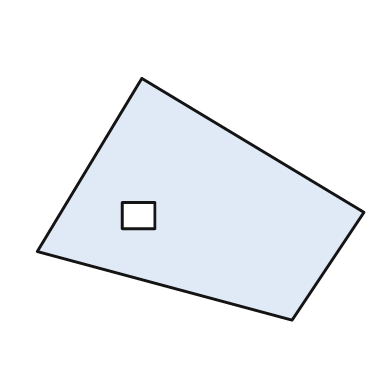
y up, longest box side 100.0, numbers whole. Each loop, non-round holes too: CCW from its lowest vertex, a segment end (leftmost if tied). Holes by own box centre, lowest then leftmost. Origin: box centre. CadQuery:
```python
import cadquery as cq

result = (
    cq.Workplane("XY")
    .moveTo(28.0, -37.0)
    .lineTo(50.0, -4.0)
    .lineTo(-18.0, 37.0)
    .lineTo(-50.0, -16.0)
    .close()
    .moveTo(-24.0, -9.0)
    .lineTo(-14.0, -9.0)
    .lineTo(-14.0, -1.0)
    .lineTo(-24.0, -1.0)
    .close()
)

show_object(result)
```